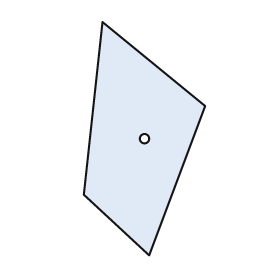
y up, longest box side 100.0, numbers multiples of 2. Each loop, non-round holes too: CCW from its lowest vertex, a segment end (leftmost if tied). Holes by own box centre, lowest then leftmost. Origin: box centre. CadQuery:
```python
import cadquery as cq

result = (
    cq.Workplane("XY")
    .moveTo(2.0, -50.0)
    .lineTo(26.0, 14.0)
    .lineTo(-18.0, 50.0)
    .lineTo(-26.0, -24.0)
    .close()
    .moveTo(0.0, 0.0)
    .circle(2.0)
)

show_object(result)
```